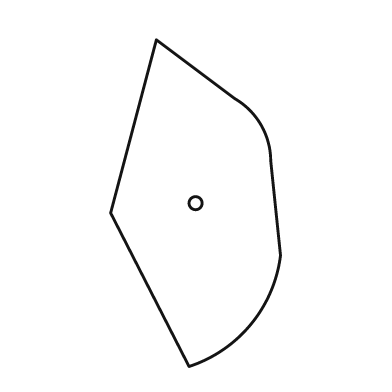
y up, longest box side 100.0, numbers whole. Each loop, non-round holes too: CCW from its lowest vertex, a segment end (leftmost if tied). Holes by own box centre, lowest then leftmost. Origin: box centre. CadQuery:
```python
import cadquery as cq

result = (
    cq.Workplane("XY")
    .moveTo(-2.0, -50.0)
    .threePointArc((17.0, -37.0), (26.0, -16.0))
    .lineTo(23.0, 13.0)
    .threePointArc((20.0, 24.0), (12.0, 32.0))
    .lineTo(-12.0, 50.0)
    .lineTo(-26.0, -3.0)
    .close()
    .moveTo(0.0, 0.0)
    .circle(2.0)
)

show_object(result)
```